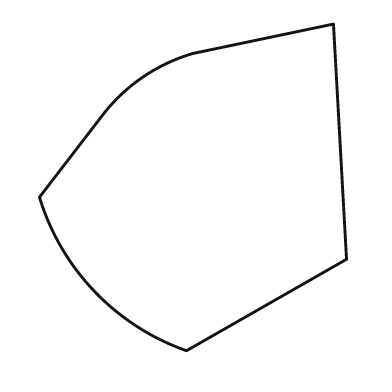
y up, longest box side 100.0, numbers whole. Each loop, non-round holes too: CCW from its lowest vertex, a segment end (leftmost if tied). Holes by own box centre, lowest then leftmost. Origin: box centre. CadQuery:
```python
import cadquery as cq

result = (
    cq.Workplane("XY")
    .moveTo(-2.0, -50.0)
    .lineTo(47.0, -22.0)
    .lineTo(43.0, 50.0)
    .lineTo(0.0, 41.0)
    .threePointArc((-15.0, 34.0), (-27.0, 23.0))
    .lineTo(-47.0, -3.0)
    .threePointArc((-30.0, -32.0), (-2.0, -50.0))
    .close()
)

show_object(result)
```